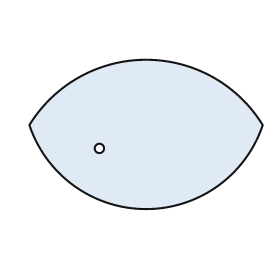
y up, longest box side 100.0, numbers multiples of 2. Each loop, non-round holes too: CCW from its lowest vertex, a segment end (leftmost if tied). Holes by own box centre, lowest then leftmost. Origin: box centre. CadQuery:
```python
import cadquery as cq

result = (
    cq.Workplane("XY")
    .moveTo(-50.0, 4.0)
    .threePointArc((0.0, -32.0), (50.0, 4.0))
    .threePointArc((0.0, 32.0), (-50.0, 4.0))
    .close()
    .moveTo(-20.0, -6.0)
    .circle(2.0)
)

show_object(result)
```